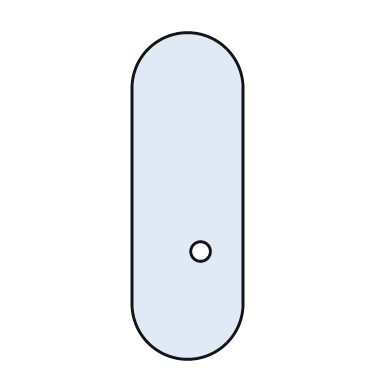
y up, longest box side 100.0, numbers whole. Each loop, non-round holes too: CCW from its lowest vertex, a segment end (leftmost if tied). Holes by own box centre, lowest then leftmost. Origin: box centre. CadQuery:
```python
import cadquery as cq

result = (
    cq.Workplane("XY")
    .moveTo(-17.0, -33.0)
    .threePointArc((0.0, -50.0), (17.0, -33.0))
    .lineTo(17.0, 33.0)
    .threePointArc((0.0, 50.0), (-17.0, 33.0))
    .close()
    .moveTo(4.0, -17.0)
    .circle(3.0)
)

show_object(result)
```